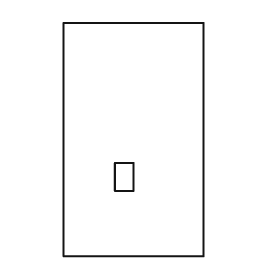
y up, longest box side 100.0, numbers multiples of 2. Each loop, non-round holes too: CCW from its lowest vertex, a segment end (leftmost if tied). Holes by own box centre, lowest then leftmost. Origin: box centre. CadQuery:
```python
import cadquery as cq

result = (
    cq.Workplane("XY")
    .moveTo(-30.0, -50.0)
    .lineTo(30.0, -50.0)
    .lineTo(30.0, 50.0)
    .lineTo(-30.0, 50.0)
    .close()
    .moveTo(-8.0, -22.0)
    .lineTo(0.0, -22.0)
    .lineTo(0.0, -10.0)
    .lineTo(-8.0, -10.0)
    .close()
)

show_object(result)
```